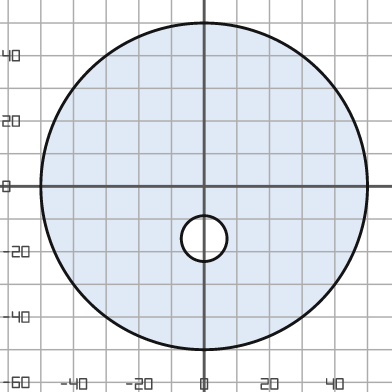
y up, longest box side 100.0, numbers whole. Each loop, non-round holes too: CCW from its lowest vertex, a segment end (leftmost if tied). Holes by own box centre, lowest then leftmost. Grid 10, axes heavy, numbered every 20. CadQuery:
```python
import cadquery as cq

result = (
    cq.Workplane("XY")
    .moveTo(0.0, 0.0)
    .circle(50.0)
    .moveTo(0.0, -16.0)
    .circle(7.0)
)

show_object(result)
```